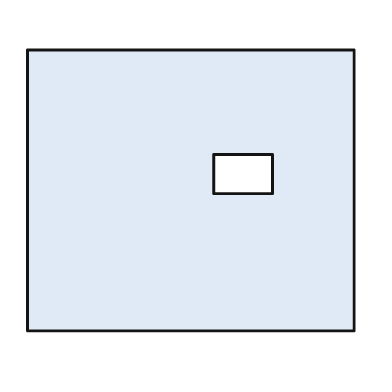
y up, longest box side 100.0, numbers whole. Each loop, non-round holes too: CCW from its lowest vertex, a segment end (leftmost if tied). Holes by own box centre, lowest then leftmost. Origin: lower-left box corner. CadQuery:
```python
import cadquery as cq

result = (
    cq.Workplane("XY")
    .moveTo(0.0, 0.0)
    .lineTo(100.0, 0.0)
    .lineTo(100.0, 86.0)
    .lineTo(0.0, 86.0)
    .close()
    .moveTo(57.0, 42.0)
    .lineTo(75.0, 42.0)
    .lineTo(75.0, 54.0)
    .lineTo(57.0, 54.0)
    .close()
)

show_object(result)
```